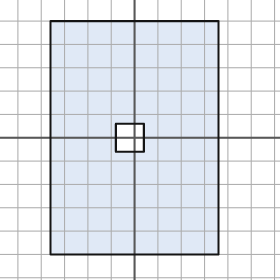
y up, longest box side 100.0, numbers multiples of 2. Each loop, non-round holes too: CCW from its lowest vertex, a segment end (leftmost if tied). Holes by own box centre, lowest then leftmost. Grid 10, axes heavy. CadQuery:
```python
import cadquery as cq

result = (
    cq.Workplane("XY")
    .moveTo(-36.0, -50.0)
    .lineTo(36.0, -50.0)
    .lineTo(36.0, 50.0)
    .lineTo(-36.0, 50.0)
    .close()
    .moveTo(-8.0, -6.0)
    .lineTo(4.0, -6.0)
    .lineTo(4.0, 6.0)
    .lineTo(-8.0, 6.0)
    .close()
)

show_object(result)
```